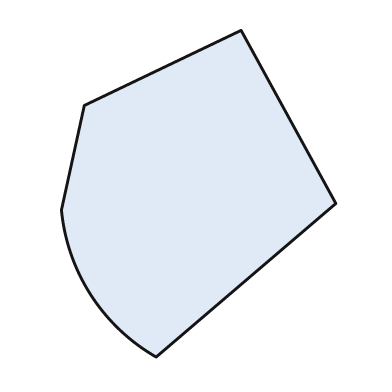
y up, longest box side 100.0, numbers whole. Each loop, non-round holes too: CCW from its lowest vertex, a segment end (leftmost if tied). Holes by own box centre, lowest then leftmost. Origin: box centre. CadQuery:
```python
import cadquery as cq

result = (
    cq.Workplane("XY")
    .moveTo(-13.0, -50.0)
    .lineTo(42.0, -3.0)
    .lineTo(13.0, 50.0)
    .lineTo(-35.0, 27.0)
    .lineTo(-42.0, -5.0)
    .threePointArc((-33.0, -31.0), (-13.0, -50.0))
    .close()
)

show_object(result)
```